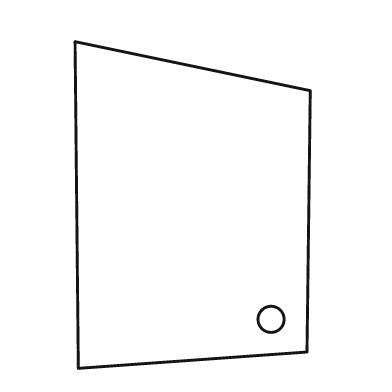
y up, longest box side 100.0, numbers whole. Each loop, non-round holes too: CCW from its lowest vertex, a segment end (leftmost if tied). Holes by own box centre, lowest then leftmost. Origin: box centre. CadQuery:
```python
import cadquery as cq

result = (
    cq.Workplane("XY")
    .moveTo(-35.0, -50.0)
    .lineTo(35.0, -45.0)
    .lineTo(36.0, 35.0)
    .lineTo(-36.0, 50.0)
    .close()
    .moveTo(24.0, -35.0)
    .circle(4.0)
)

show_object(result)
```